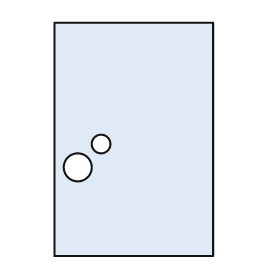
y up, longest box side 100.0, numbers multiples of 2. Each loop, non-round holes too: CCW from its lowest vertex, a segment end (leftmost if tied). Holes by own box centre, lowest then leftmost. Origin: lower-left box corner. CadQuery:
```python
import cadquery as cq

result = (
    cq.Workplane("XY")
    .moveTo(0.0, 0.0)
    .lineTo(68.0, 0.0)
    .lineTo(68.0, 100.0)
    .lineTo(0.0, 100.0)
    .close()
    .moveTo(10.0, 38.0)
    .circle(6.0)
    .moveTo(20.0, 48.0)
    .circle(4.0)
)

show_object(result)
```